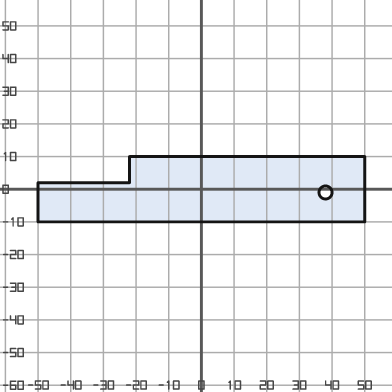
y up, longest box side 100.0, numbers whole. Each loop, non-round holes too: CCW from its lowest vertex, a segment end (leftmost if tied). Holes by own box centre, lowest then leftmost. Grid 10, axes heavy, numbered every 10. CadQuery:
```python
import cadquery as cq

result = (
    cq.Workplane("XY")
    .moveTo(-50.0, -10.0)
    .lineTo(50.0, -10.0)
    .lineTo(50.0, 10.0)
    .lineTo(-22.0, 10.0)
    .lineTo(-22.0, 2.0)
    .lineTo(-50.0, 2.0)
    .close()
    .moveTo(38.0, -1.0)
    .circle(2.0)
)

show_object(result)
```